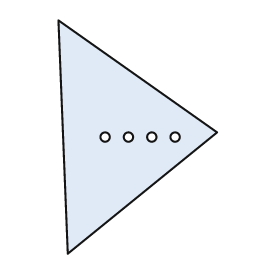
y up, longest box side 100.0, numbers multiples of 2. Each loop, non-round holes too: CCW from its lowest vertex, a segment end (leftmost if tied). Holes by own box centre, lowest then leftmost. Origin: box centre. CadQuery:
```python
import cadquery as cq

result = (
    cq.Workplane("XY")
    .moveTo(-30.0, -50.0)
    .lineTo(34.0, 2.0)
    .lineTo(-34.0, 50.0)
    .close()
    .moveTo(-14.0, 0.0)
    .circle(2.0)
    .moveTo(-4.0, 0.0)
    .circle(2.0)
    .moveTo(6.0, 0.0)
    .circle(2.0)
    .moveTo(16.0, 0.0)
    .circle(2.0)
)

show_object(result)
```